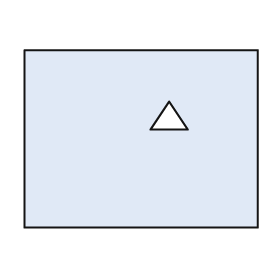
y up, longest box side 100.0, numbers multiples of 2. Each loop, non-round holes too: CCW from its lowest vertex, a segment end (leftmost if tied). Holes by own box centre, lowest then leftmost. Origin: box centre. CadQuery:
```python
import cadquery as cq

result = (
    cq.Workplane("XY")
    .moveTo(-50.0, -38.0)
    .lineTo(50.0, -38.0)
    .lineTo(50.0, 38.0)
    .lineTo(-50.0, 38.0)
    .close()
    .moveTo(4.0, 4.0)
    .lineTo(20.0, 4.0)
    .lineTo(12.0, 16.0)
    .close()
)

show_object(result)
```